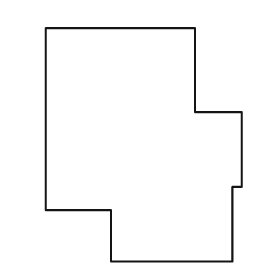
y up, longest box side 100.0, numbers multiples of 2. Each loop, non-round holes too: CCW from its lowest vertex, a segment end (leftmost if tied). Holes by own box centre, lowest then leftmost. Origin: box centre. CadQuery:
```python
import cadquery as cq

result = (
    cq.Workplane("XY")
    .moveTo(-14.0, -50.0)
    .lineTo(38.0, -50.0)
    .lineTo(38.0, -18.0)
    .lineTo(42.0, -18.0)
    .lineTo(42.0, 14.0)
    .lineTo(22.0, 14.0)
    .lineTo(22.0, 50.0)
    .lineTo(-42.0, 50.0)
    .lineTo(-42.0, -28.0)
    .lineTo(-14.0, -28.0)
    .close()
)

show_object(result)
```